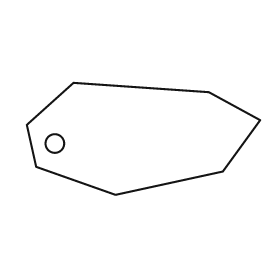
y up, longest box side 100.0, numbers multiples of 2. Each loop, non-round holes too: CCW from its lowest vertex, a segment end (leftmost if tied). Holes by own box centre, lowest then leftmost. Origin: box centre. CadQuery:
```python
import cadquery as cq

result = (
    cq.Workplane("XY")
    .moveTo(-12.0, -24.0)
    .lineTo(34.0, -14.0)
    .lineTo(50.0, 8.0)
    .lineTo(28.0, 20.0)
    .lineTo(-30.0, 24.0)
    .lineTo(-50.0, 6.0)
    .lineTo(-46.0, -12.0)
    .close()
    .moveTo(-38.0, -2.0)
    .circle(4.0)
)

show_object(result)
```